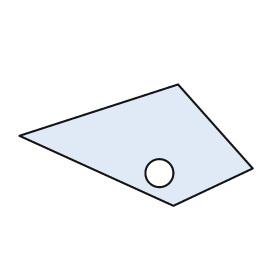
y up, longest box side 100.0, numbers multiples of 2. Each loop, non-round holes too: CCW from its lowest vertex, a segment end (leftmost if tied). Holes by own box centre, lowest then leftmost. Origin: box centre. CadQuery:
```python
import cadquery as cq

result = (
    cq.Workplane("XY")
    .moveTo(16.0, -26.0)
    .lineTo(50.0, -10.0)
    .lineTo(18.0, 26.0)
    .lineTo(-50.0, 4.0)
    .close()
    .moveTo(10.0, -12.0)
    .circle(6.0)
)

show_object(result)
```